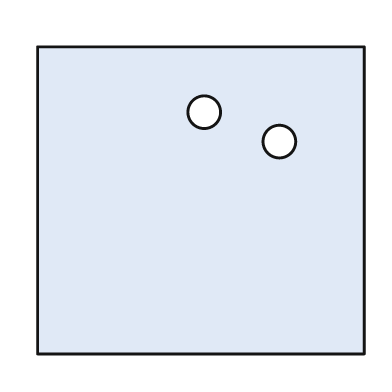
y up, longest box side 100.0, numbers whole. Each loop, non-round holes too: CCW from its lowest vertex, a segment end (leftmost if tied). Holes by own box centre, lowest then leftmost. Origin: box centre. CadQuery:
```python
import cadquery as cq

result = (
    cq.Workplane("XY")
    .moveTo(-50.0, -47.0)
    .lineTo(50.0, -47.0)
    .lineTo(50.0, 47.0)
    .lineTo(-50.0, 47.0)
    .close()
    .moveTo(24.0, 18.0)
    .circle(5.0)
    .moveTo(1.0, 27.0)
    .circle(5.0)
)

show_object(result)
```